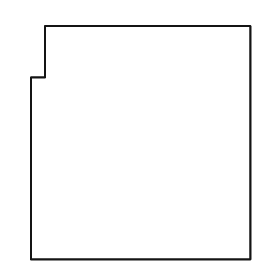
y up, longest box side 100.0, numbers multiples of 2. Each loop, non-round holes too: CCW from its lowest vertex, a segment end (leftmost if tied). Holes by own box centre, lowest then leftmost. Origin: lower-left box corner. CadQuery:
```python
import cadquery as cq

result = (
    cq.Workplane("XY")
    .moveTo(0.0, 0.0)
    .lineTo(94.0, 0.0)
    .lineTo(94.0, 100.0)
    .lineTo(6.0, 100.0)
    .lineTo(6.0, 78.0)
    .lineTo(0.0, 78.0)
    .close()
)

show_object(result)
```